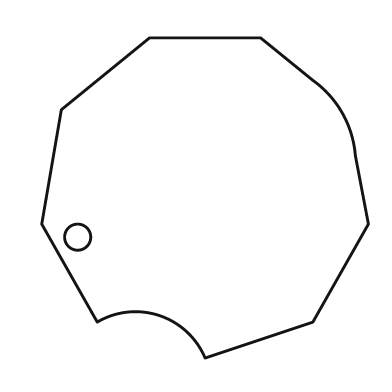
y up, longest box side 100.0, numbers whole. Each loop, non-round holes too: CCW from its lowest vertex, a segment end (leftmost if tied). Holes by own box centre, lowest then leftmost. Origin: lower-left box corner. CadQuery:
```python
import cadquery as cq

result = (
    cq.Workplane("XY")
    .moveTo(50.0, 0.0)
    .lineTo(83.0, 11.0)
    .lineTo(100.0, 41.0)
    .lineTo(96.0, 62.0)
    .threePointArc((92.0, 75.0), (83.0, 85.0))
    .lineTo(67.0, 98.0)
    .lineTo(33.0, 98.0)
    .lineTo(6.0, 76.0)
    .lineTo(0.0, 41.0)
    .lineTo(17.0, 11.0)
    .threePointArc((36.0, 13.0), (50.0, 0.0))
    .close()
    .moveTo(11.0, 37.0)
    .circle(4.0)
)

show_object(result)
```